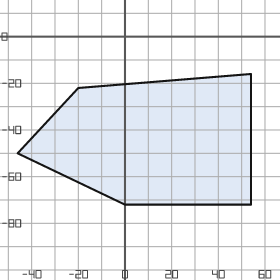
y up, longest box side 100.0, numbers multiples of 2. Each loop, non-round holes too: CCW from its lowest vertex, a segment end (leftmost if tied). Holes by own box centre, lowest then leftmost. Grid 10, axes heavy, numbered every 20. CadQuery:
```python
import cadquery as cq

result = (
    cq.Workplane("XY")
    .moveTo(0.0, -72.0)
    .lineTo(54.0, -72.0)
    .lineTo(54.0, -16.0)
    .lineTo(-20.0, -22.0)
    .lineTo(-46.0, -50.0)
    .close()
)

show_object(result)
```